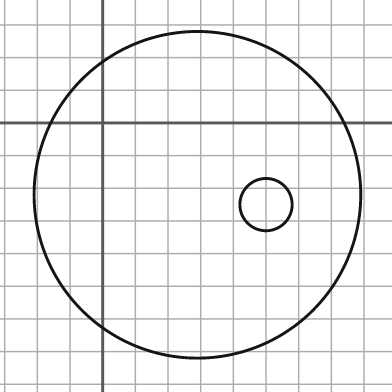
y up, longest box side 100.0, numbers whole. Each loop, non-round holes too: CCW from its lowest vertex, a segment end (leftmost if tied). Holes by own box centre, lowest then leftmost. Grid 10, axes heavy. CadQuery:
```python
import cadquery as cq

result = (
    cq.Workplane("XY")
    .moveTo(29.0, -22.0)
    .circle(50.0)
    .moveTo(50.0, -25.0)
    .circle(8.0)
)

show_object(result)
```